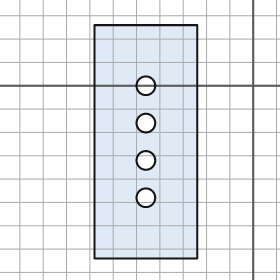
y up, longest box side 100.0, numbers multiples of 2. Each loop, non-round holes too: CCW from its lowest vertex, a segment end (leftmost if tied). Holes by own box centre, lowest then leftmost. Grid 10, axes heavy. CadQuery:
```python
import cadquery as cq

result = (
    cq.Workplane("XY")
    .moveTo(-68.0, -74.0)
    .lineTo(-24.0, -74.0)
    .lineTo(-24.0, 26.0)
    .lineTo(-68.0, 26.0)
    .close()
    .moveTo(-46.0, -48.0)
    .circle(4.0)
    .moveTo(-46.0, -32.0)
    .circle(4.0)
    .moveTo(-46.0, -16.0)
    .circle(4.0)
    .moveTo(-46.0, 0.0)
    .circle(4.0)
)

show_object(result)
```